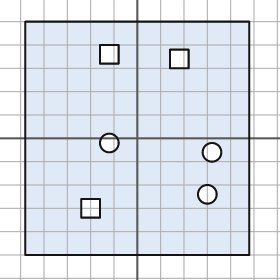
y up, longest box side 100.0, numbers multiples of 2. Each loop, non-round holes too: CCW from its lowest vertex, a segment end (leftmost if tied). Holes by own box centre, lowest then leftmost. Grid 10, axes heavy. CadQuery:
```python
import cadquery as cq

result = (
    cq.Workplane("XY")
    .moveTo(-48.0, -50.0)
    .lineTo(48.0, -50.0)
    .lineTo(48.0, 50.0)
    .lineTo(-48.0, 50.0)
    .close()
    .moveTo(-24.0, -34.0)
    .lineTo(-16.0, -34.0)
    .lineTo(-16.0, -26.0)
    .lineTo(-24.0, -26.0)
    .close()
    .moveTo(30.0, -24.0)
    .circle(4.0)
    .moveTo(32.0, -6.0)
    .circle(4.0)
    .moveTo(-12.0, -2.0)
    .circle(4.0)
    .moveTo(14.0, 30.0)
    .lineTo(22.0, 30.0)
    .lineTo(22.0, 38.0)
    .lineTo(14.0, 38.0)
    .close()
    .moveTo(-16.0, 32.0)
    .lineTo(-8.0, 32.0)
    .lineTo(-8.0, 40.0)
    .lineTo(-16.0, 40.0)
    .close()
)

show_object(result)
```